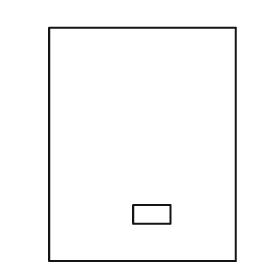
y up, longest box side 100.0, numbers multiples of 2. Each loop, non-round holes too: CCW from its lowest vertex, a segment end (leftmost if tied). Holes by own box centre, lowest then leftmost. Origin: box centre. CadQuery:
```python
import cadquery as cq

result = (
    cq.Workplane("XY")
    .moveTo(-40.0, -50.0)
    .lineTo(40.0, -50.0)
    .lineTo(40.0, 50.0)
    .lineTo(-40.0, 50.0)
    .close()
    .moveTo(-4.0, -34.0)
    .lineTo(12.0, -34.0)
    .lineTo(12.0, -26.0)
    .lineTo(-4.0, -26.0)
    .close()
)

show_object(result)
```